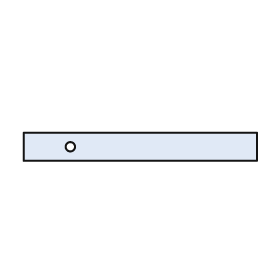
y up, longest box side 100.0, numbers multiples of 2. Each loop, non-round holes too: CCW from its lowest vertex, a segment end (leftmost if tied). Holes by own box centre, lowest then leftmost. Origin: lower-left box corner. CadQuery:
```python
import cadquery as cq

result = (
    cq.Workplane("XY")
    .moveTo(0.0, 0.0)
    .lineTo(100.0, 0.0)
    .lineTo(100.0, 12.0)
    .lineTo(0.0, 12.0)
    .close()
    .moveTo(20.0, 6.0)
    .circle(2.0)
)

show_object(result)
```